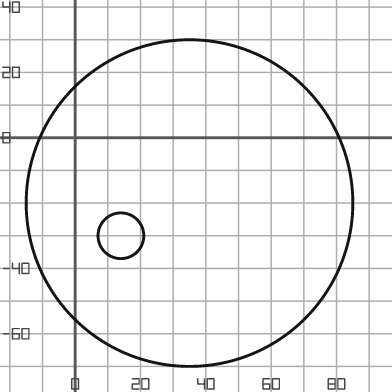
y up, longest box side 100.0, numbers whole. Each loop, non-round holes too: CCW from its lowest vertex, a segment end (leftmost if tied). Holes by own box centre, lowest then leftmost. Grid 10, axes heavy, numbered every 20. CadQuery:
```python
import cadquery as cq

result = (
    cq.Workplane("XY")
    .moveTo(35.0, -20.0)
    .circle(50.0)
    .moveTo(14.0, -30.0)
    .circle(7.0)
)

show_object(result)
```